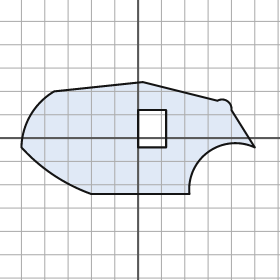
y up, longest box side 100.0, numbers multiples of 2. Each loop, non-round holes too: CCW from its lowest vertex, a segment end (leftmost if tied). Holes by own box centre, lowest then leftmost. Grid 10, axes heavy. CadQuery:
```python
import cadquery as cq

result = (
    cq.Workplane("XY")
    .moveTo(-20.0, -24.0)
    .lineTo(22.0, -24.0)
    .threePointArc((30.0, -6.0), (50.0, -4.0))
    .lineTo(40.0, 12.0)
    .threePointArc((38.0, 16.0), (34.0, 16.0))
    .lineTo(2.0, 24.0)
    .lineTo(-36.0, 20.0)
    .threePointArc((-46.0, 10.0), (-50.0, -4.0))
    .threePointArc((-36.0, -16.0), (-20.0, -24.0))
    .close()
    .moveTo(0.0, -4.0)
    .lineTo(12.0, -4.0)
    .lineTo(12.0, 12.0)
    .lineTo(0.0, 12.0)
    .close()
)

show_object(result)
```